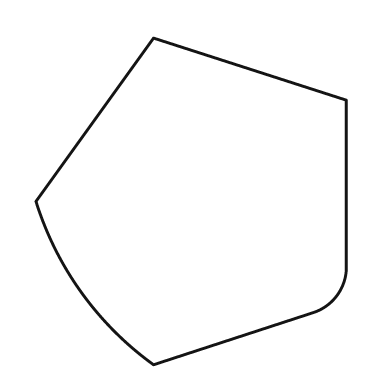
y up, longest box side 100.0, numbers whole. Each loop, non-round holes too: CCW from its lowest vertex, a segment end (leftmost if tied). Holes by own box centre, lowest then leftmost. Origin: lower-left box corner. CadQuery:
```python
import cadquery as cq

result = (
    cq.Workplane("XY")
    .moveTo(36.0, 0.0)
    .lineTo(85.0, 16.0)
    .threePointArc((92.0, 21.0), (95.0, 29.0))
    .lineTo(95.0, 81.0)
    .lineTo(36.0, 100.0)
    .lineTo(0.0, 50.0)
    .threePointArc((14.0, 22.0), (36.0, 0.0))
    .close()
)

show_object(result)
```